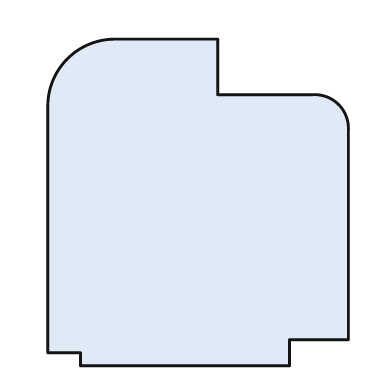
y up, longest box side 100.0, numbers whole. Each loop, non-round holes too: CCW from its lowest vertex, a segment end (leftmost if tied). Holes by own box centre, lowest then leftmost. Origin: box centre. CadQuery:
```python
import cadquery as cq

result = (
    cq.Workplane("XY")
    .moveTo(-36.0, -50.0)
    .lineTo(28.0, -50.0)
    .lineTo(28.0, -42.0)
    .lineTo(46.0, -42.0)
    .lineTo(46.0, 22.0)
    .threePointArc((43.0, 30.0), (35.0, 33.0))
    .lineTo(6.0, 33.0)
    .lineTo(6.0, 50.0)
    .lineTo(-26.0, 50.0)
    .threePointArc((-40.0, 44.0), (-46.0, 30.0))
    .lineTo(-46.0, -46.0)
    .lineTo(-36.0, -46.0)
    .close()
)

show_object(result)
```